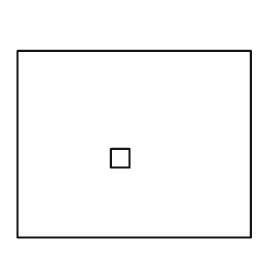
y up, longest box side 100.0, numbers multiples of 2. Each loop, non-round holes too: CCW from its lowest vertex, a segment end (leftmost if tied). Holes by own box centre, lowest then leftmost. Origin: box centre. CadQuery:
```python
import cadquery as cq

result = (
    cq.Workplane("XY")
    .moveTo(-50.0, -40.0)
    .lineTo(50.0, -40.0)
    .lineTo(50.0, 40.0)
    .lineTo(-50.0, 40.0)
    .close()
    .moveTo(-10.0, -10.0)
    .lineTo(-2.0, -10.0)
    .lineTo(-2.0, -2.0)
    .lineTo(-10.0, -2.0)
    .close()
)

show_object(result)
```